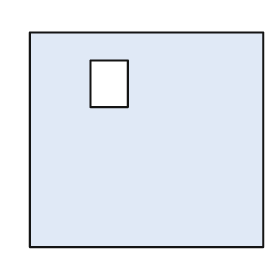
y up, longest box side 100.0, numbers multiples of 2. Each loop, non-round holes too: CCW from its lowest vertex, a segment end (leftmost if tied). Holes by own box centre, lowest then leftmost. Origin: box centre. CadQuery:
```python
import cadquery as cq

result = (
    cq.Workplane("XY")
    .moveTo(-50.0, -46.0)
    .lineTo(50.0, -46.0)
    .lineTo(50.0, 46.0)
    .lineTo(-50.0, 46.0)
    .close()
    .moveTo(-24.0, 14.0)
    .lineTo(-8.0, 14.0)
    .lineTo(-8.0, 34.0)
    .lineTo(-24.0, 34.0)
    .close()
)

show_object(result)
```